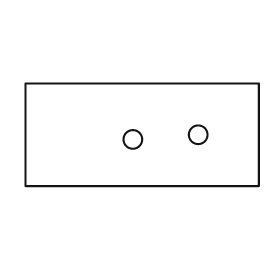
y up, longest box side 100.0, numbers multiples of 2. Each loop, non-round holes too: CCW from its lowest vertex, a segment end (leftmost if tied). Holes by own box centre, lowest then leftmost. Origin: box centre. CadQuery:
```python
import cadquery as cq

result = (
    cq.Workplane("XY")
    .moveTo(-50.0, -22.0)
    .lineTo(50.0, -22.0)
    .lineTo(50.0, 22.0)
    .lineTo(-50.0, 22.0)
    .close()
    .moveTo(-4.0, -2.0)
    .circle(4.0)
    .moveTo(24.0, 0.0)
    .circle(4.0)
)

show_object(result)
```